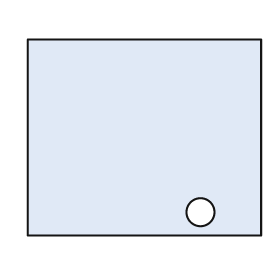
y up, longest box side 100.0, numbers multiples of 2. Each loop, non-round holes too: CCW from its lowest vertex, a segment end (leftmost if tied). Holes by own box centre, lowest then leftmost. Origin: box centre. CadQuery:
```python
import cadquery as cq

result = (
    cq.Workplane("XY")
    .moveTo(-50.0, -42.0)
    .lineTo(50.0, -42.0)
    .lineTo(50.0, 42.0)
    .lineTo(-50.0, 42.0)
    .close()
    .moveTo(24.0, -32.0)
    .circle(6.0)
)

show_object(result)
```